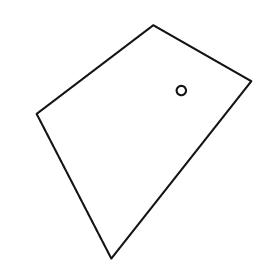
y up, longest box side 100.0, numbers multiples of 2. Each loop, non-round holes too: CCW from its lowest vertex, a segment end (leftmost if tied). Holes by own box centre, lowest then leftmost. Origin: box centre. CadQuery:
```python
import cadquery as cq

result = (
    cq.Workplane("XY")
    .moveTo(-14.0, -50.0)
    .lineTo(46.0, 26.0)
    .lineTo(4.0, 50.0)
    .lineTo(-46.0, 12.0)
    .close()
    .moveTo(16.0, 22.0)
    .circle(2.0)
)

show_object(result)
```